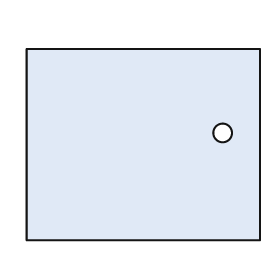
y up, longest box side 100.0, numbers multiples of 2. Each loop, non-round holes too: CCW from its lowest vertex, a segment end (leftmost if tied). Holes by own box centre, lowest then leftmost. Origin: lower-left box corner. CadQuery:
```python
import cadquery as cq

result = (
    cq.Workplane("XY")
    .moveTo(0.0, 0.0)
    .lineTo(100.0, 0.0)
    .lineTo(100.0, 82.0)
    .lineTo(0.0, 82.0)
    .close()
    .moveTo(84.0, 46.0)
    .circle(4.0)
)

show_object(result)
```